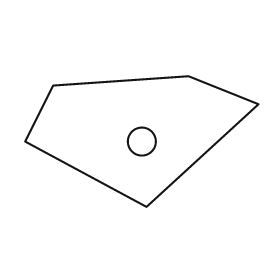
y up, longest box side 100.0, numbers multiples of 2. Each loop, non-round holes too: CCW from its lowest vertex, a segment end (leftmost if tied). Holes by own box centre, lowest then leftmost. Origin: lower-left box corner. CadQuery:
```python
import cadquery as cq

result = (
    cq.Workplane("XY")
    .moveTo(52.0, 0.0)
    .lineTo(100.0, 44.0)
    .lineTo(70.0, 56.0)
    .lineTo(12.0, 52.0)
    .lineTo(0.0, 28.0)
    .close()
    .moveTo(50.0, 28.0)
    .circle(6.0)
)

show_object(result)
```